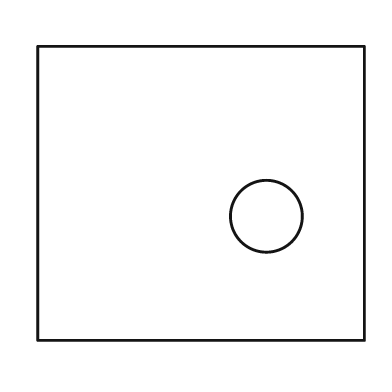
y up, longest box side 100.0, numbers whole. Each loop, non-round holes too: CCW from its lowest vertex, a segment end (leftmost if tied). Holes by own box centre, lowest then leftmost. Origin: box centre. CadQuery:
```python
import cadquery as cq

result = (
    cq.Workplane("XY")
    .moveTo(-50.0, -45.0)
    .lineTo(50.0, -45.0)
    .lineTo(50.0, 45.0)
    .lineTo(-50.0, 45.0)
    .close()
    .moveTo(20.0, -7.0)
    .circle(11.0)
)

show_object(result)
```